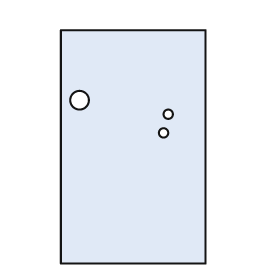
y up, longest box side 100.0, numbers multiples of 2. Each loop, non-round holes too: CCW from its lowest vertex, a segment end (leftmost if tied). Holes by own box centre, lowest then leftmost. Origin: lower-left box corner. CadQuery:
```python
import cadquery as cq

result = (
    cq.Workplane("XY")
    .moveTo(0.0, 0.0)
    .lineTo(62.0, 0.0)
    .lineTo(62.0, 100.0)
    .lineTo(0.0, 100.0)
    .close()
    .moveTo(44.0, 56.0)
    .circle(2.0)
    .moveTo(46.0, 64.0)
    .circle(2.0)
    .moveTo(8.0, 70.0)
    .circle(4.0)
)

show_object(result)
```